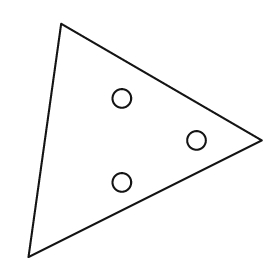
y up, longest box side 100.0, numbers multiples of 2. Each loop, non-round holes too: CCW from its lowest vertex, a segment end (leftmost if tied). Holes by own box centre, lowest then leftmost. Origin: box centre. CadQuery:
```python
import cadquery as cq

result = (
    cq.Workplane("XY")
    .moveTo(-50.0, -50.0)
    .lineTo(50.0, 0.0)
    .lineTo(-36.0, 50.0)
    .close()
    .moveTo(-10.0, -18.0)
    .circle(4.0)
    .moveTo(22.0, 0.0)
    .circle(4.0)
    .moveTo(-10.0, 18.0)
    .circle(4.0)
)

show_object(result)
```